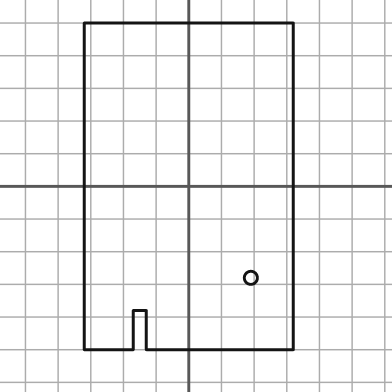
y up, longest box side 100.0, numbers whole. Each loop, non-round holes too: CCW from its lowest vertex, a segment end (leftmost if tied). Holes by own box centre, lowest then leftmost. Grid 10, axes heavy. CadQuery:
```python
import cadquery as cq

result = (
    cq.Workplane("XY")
    .moveTo(-32.0, -50.0)
    .lineTo(-17.0, -50.0)
    .lineTo(-17.0, -38.0)
    .lineTo(-13.0, -38.0)
    .lineTo(-13.0, -50.0)
    .lineTo(32.0, -50.0)
    .lineTo(32.0, 50.0)
    .lineTo(-32.0, 50.0)
    .close()
    .moveTo(19.0, -28.0)
    .circle(2.0)
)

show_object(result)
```